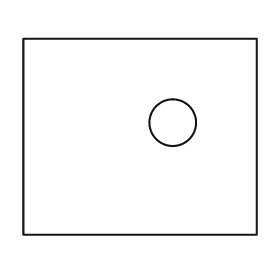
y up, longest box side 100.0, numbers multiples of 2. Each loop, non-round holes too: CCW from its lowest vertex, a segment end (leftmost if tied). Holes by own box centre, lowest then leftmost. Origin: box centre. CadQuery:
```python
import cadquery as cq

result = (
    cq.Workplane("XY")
    .moveTo(-50.0, -42.0)
    .lineTo(50.0, -42.0)
    .lineTo(50.0, 42.0)
    .lineTo(-50.0, 42.0)
    .close()
    .moveTo(14.0, 6.0)
    .circle(10.0)
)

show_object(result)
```